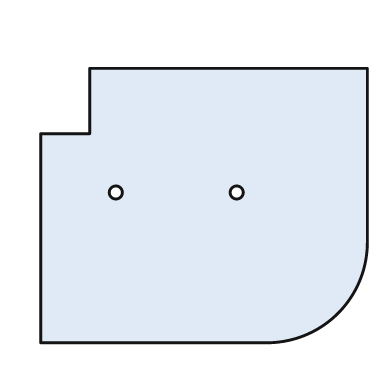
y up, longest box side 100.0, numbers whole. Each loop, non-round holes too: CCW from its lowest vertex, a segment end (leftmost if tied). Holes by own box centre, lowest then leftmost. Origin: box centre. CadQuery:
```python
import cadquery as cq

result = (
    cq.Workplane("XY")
    .moveTo(-50.0, -42.0)
    .lineTo(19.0, -42.0)
    .threePointArc((41.0, -33.0), (50.0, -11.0))
    .lineTo(50.0, 42.0)
    .lineTo(-35.0, 42.0)
    .lineTo(-35.0, 22.0)
    .lineTo(-50.0, 22.0)
    .close()
    .moveTo(-27.0, 4.0)
    .circle(2.0)
    .moveTo(10.0, 4.0)
    .circle(2.0)
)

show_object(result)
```